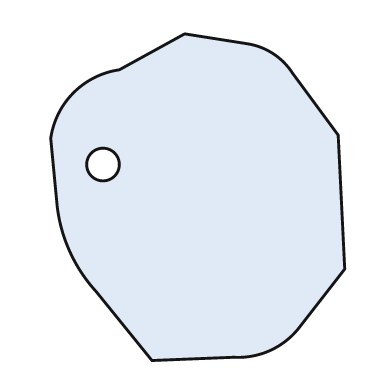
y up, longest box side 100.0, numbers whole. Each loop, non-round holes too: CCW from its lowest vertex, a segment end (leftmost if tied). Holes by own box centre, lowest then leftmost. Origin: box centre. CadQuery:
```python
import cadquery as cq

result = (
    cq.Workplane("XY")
    .moveTo(-14.0, -50.0)
    .lineTo(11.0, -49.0)
    .threePointArc((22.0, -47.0), (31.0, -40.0))
    .lineTo(45.0, -22.0)
    .lineTo(43.0, 19.0)
    .lineTo(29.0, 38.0)
    .threePointArc((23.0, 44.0), (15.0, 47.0))
    .lineTo(-4.0, 50.0)
    .lineTo(-24.0, 39.0)
    .threePointArc((-38.0, 32.0), (-45.0, 18.0))
    .lineTo(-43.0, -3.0)
    .threePointArc((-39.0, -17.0), (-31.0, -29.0))
    .close()
    .moveTo(-29.0, 10.0)
    .circle(5.0)
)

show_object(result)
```